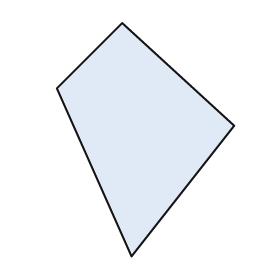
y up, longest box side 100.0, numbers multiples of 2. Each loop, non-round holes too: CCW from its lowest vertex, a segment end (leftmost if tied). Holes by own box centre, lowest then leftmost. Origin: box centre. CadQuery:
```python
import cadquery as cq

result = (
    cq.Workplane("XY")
    .moveTo(-6.0, -50.0)
    .lineTo(38.0, 6.0)
    .lineTo(-10.0, 50.0)
    .lineTo(-38.0, 22.0)
    .close()
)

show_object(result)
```